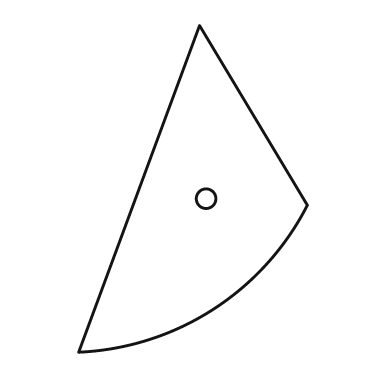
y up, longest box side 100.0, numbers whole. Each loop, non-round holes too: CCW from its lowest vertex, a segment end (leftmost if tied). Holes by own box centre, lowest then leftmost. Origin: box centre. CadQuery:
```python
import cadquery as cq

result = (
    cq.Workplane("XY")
    .moveTo(-35.0, -50.0)
    .threePointArc((6.0, -37.0), (35.0, -5.0))
    .lineTo(2.0, 50.0)
    .close()
    .moveTo(4.0, -3.0)
    .circle(3.0)
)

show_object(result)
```